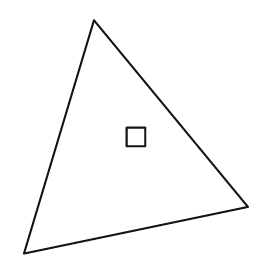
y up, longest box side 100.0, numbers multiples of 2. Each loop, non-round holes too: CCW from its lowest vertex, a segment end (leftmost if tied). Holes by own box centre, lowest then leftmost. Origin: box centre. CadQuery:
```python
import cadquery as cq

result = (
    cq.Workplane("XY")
    .moveTo(-48.0, -50.0)
    .lineTo(48.0, -30.0)
    .lineTo(-18.0, 50.0)
    .close()
    .moveTo(-4.0, -4.0)
    .lineTo(4.0, -4.0)
    .lineTo(4.0, 4.0)
    .lineTo(-4.0, 4.0)
    .close()
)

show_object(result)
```